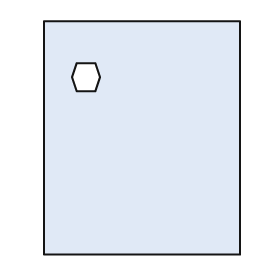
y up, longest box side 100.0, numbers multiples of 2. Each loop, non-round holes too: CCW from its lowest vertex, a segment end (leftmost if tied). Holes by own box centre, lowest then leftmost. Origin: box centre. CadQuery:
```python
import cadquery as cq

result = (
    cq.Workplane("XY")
    .moveTo(-42.0, -50.0)
    .lineTo(42.0, -50.0)
    .lineTo(42.0, 50.0)
    .lineTo(-42.0, 50.0)
    .close()
    .moveTo(-28.0, 20.0)
    .lineTo(-20.0, 20.0)
    .lineTo(-18.0, 26.0)
    .lineTo(-20.0, 32.0)
    .lineTo(-28.0, 32.0)
    .lineTo(-30.0, 26.0)
    .close()
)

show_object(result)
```